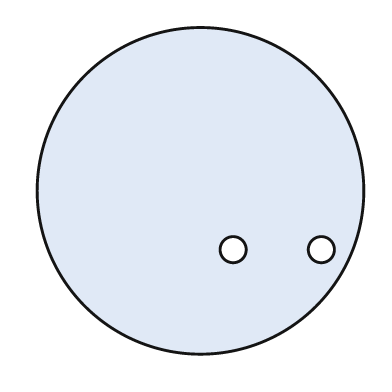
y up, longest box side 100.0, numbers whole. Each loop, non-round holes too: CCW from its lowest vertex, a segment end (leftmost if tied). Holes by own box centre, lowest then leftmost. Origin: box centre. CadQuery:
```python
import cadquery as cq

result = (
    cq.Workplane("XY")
    .moveTo(0.0, 0.0)
    .circle(50.0)
    .moveTo(10.0, -18.0)
    .circle(4.0)
    .moveTo(37.0, -18.0)
    .circle(4.0)
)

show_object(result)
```